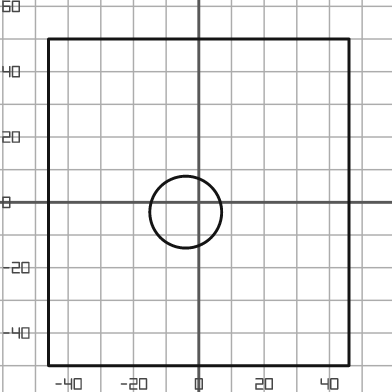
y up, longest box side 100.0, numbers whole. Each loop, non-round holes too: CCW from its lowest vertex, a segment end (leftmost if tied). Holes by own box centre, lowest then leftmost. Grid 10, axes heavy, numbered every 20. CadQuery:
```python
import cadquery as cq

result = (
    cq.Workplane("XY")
    .moveTo(-46.0, -50.0)
    .lineTo(46.0, -50.0)
    .lineTo(46.0, 50.0)
    .lineTo(-46.0, 50.0)
    .close()
    .moveTo(-4.0, -3.0)
    .circle(11.0)
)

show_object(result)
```